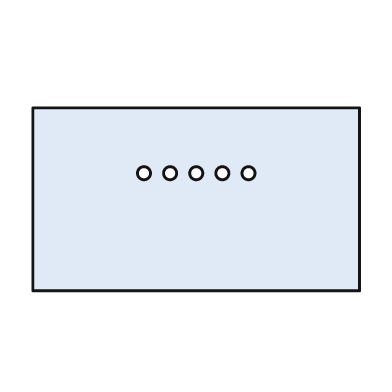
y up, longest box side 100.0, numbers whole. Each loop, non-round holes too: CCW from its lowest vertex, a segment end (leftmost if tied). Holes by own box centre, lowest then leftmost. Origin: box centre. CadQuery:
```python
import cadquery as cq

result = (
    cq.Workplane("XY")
    .moveTo(-50.0, -28.0)
    .lineTo(50.0, -28.0)
    .lineTo(50.0, 28.0)
    .lineTo(-50.0, 28.0)
    .close()
    .moveTo(-16.0, 8.0)
    .circle(2.0)
    .moveTo(-8.0, 8.0)
    .circle(2.0)
    .moveTo(0.0, 8.0)
    .circle(2.0)
    .moveTo(8.0, 8.0)
    .circle(2.0)
    .moveTo(16.0, 8.0)
    .circle(2.0)
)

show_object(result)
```